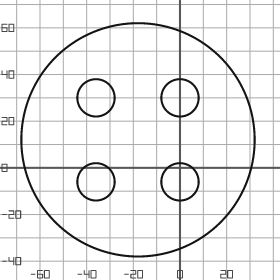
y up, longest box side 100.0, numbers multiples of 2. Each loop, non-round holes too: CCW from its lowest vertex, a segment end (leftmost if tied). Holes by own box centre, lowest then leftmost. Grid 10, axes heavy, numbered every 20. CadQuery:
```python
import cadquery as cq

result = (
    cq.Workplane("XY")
    .moveTo(-18.0, 12.0)
    .circle(50.0)
    .moveTo(-36.0, -6.0)
    .circle(8.0)
    .moveTo(0.0, -6.0)
    .circle(8.0)
    .moveTo(-36.0, 30.0)
    .circle(8.0)
    .moveTo(0.0, 30.0)
    .circle(8.0)
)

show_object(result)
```